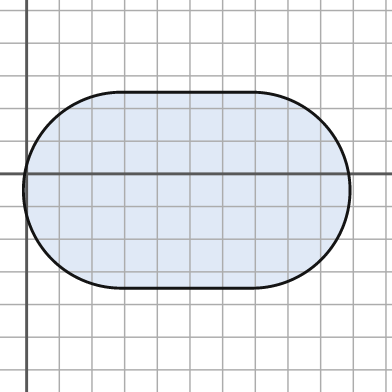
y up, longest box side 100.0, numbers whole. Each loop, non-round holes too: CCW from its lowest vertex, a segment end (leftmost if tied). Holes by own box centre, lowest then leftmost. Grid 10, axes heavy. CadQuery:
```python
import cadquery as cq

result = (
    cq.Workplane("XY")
    .moveTo(29.0, -35.0)
    .lineTo(69.0, -35.0)
    .threePointArc((99.0, -5.0), (69.0, 25.0))
    .lineTo(29.0, 25.0)
    .threePointArc((-1.0, -5.0), (29.0, -35.0))
    .close()
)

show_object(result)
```